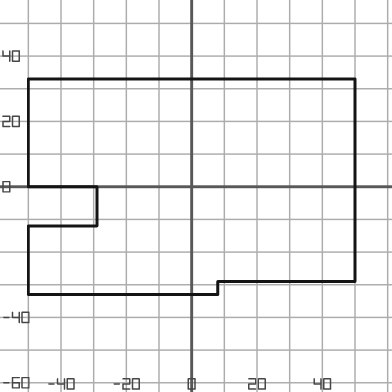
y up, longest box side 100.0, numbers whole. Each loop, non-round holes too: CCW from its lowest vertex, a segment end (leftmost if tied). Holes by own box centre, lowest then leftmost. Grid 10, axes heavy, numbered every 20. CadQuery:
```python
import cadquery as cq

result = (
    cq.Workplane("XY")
    .moveTo(-50.0, -33.0)
    .lineTo(8.0, -33.0)
    .lineTo(8.0, -29.0)
    .lineTo(50.0, -29.0)
    .lineTo(50.0, 33.0)
    .lineTo(-50.0, 33.0)
    .lineTo(-50.0, 0.0)
    .lineTo(-29.0, 0.0)
    .lineTo(-29.0, -12.0)
    .lineTo(-50.0, -12.0)
    .close()
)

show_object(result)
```